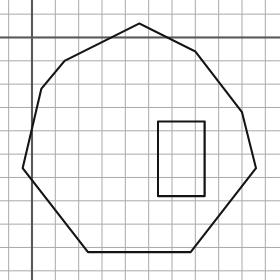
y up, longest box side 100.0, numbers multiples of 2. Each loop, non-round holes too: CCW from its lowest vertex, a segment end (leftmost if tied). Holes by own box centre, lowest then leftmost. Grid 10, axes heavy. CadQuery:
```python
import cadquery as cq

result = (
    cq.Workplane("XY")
    .moveTo(24.0, -92.0)
    .lineTo(68.0, -92.0)
    .lineTo(96.0, -56.0)
    .lineTo(90.0, -32.0)
    .lineTo(70.0, -6.0)
    .lineTo(46.0, 6.0)
    .lineTo(14.0, -10.0)
    .lineTo(4.0, -22.0)
    .lineTo(-4.0, -56.0)
    .close()
    .moveTo(54.0, -68.0)
    .lineTo(74.0, -68.0)
    .lineTo(74.0, -36.0)
    .lineTo(54.0, -36.0)
    .close()
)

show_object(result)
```